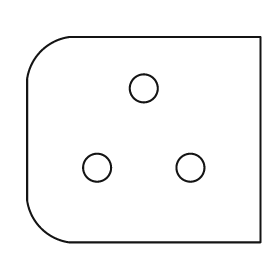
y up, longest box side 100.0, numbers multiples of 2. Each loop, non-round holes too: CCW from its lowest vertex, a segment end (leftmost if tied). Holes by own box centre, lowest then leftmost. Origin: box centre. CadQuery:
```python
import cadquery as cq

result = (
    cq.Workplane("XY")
    .moveTo(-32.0, -44.0)
    .lineTo(50.0, -44.0)
    .lineTo(50.0, 44.0)
    .lineTo(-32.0, 44.0)
    .threePointArc((-44.0, 38.0), (-50.0, 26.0))
    .lineTo(-50.0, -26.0)
    .threePointArc((-44.0, -38.0), (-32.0, -44.0))
    .close()
    .moveTo(-20.0, -12.0)
    .circle(6.0)
    .moveTo(20.0, -12.0)
    .circle(6.0)
    .moveTo(0.0, 22.0)
    .circle(6.0)
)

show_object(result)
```